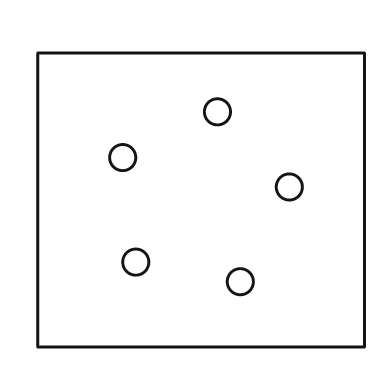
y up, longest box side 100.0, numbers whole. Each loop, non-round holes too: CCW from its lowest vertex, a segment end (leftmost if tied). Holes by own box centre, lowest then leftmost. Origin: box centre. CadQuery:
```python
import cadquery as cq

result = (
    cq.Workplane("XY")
    .moveTo(-50.0, -45.0)
    .lineTo(50.0, -45.0)
    .lineTo(50.0, 45.0)
    .lineTo(-50.0, 45.0)
    .close()
    .moveTo(12.0, -25.0)
    .circle(4.0)
    .moveTo(-20.0, -19.0)
    .circle(4.0)
    .moveTo(27.0, 4.0)
    .circle(4.0)
    .moveTo(-24.0, 13.0)
    .circle(4.0)
    .moveTo(5.0, 27.0)
    .circle(4.0)
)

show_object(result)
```